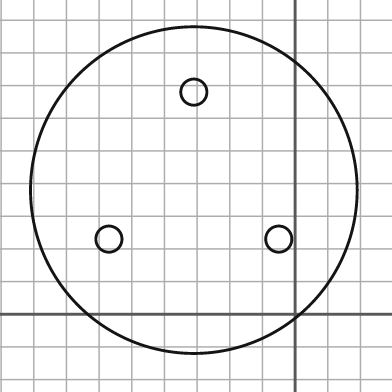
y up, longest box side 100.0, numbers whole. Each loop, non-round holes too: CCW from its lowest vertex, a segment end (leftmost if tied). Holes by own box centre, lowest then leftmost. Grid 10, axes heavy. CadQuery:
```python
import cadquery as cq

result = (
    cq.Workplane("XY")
    .moveTo(-31.0, 38.0)
    .circle(50.0)
    .moveTo(-57.0, 23.0)
    .circle(4.0)
    .moveTo(-5.0, 23.0)
    .circle(4.0)
    .moveTo(-31.0, 68.0)
    .circle(4.0)
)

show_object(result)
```